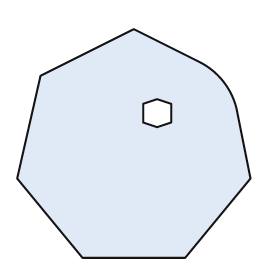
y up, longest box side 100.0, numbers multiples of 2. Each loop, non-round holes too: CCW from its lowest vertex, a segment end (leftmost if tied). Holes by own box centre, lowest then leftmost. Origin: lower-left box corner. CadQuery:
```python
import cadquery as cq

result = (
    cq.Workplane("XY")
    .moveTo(28.0, 0.0)
    .lineTo(72.0, 0.0)
    .lineTo(100.0, 34.0)
    .lineTo(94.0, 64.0)
    .threePointArc((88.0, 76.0), (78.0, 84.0))
    .lineTo(50.0, 98.0)
    .lineTo(10.0, 78.0)
    .lineTo(0.0, 34.0)
    .close()
    .moveTo(60.0, 56.0)
    .lineTo(66.0, 58.0)
    .lineTo(66.0, 66.0)
    .lineTo(60.0, 68.0)
    .lineTo(54.0, 66.0)
    .lineTo(54.0, 58.0)
    .close()
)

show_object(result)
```